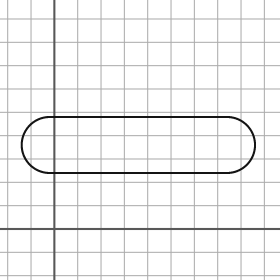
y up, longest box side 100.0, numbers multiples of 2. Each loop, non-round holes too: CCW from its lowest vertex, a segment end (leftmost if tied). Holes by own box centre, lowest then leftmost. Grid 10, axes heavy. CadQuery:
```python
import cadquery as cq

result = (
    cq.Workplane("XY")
    .moveTo(-2.0, 24.0)
    .lineTo(74.0, 24.0)
    .threePointArc((86.0, 36.0), (74.0, 48.0))
    .lineTo(-2.0, 48.0)
    .threePointArc((-14.0, 36.0), (-2.0, 24.0))
    .close()
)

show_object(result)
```